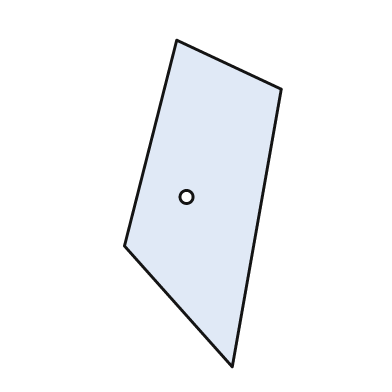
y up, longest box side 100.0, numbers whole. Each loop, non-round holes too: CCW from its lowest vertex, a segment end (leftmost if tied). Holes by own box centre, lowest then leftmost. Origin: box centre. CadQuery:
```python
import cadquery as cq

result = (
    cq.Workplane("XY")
    .moveTo(9.0, -50.0)
    .lineTo(24.0, 35.0)
    .lineTo(-8.0, 50.0)
    .lineTo(-24.0, -13.0)
    .close()
    .moveTo(-5.0, 2.0)
    .circle(2.0)
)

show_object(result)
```